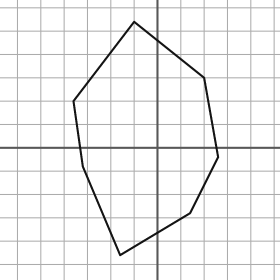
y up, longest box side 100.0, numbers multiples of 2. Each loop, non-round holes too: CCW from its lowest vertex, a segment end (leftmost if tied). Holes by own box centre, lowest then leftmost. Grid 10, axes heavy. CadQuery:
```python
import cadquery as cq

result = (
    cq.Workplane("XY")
    .moveTo(-16.0, -46.0)
    .lineTo(14.0, -28.0)
    .lineTo(26.0, -4.0)
    .lineTo(20.0, 30.0)
    .lineTo(-10.0, 54.0)
    .lineTo(-36.0, 20.0)
    .lineTo(-32.0, -8.0)
    .close()
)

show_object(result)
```